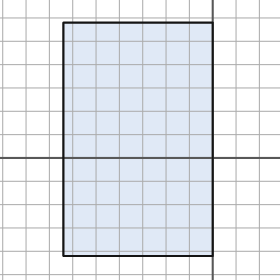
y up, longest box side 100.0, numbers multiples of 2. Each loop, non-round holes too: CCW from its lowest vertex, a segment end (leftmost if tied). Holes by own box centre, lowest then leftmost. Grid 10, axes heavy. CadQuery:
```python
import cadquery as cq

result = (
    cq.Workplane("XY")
    .moveTo(-64.0, -42.0)
    .lineTo(0.0, -42.0)
    .lineTo(0.0, 58.0)
    .lineTo(-64.0, 58.0)
    .close()
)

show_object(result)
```